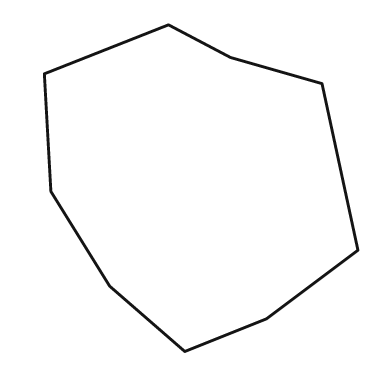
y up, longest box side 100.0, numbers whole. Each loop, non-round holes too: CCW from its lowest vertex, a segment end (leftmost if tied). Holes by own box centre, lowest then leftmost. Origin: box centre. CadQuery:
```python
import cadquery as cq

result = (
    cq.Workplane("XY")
    .moveTo(-5.0, -50.0)
    .lineTo(20.0, -40.0)
    .lineTo(48.0, -19.0)
    .lineTo(37.0, 32.0)
    .lineTo(9.0, 40.0)
    .lineTo(-10.0, 50.0)
    .lineTo(-48.0, 35.0)
    .lineTo(-46.0, -1.0)
    .lineTo(-28.0, -30.0)
    .close()
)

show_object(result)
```